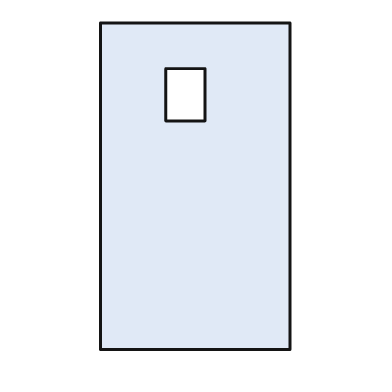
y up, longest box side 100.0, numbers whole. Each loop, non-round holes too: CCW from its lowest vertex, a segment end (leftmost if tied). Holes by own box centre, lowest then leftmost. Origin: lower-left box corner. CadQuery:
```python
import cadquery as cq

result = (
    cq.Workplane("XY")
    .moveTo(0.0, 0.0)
    .lineTo(58.0, 0.0)
    .lineTo(58.0, 100.0)
    .lineTo(0.0, 100.0)
    .close()
    .moveTo(20.0, 70.0)
    .lineTo(32.0, 70.0)
    .lineTo(32.0, 86.0)
    .lineTo(20.0, 86.0)
    .close()
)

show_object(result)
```